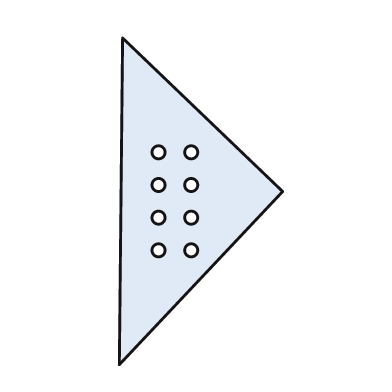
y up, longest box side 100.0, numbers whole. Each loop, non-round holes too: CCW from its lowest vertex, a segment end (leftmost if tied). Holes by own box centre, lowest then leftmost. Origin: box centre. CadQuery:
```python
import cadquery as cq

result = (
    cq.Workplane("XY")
    .moveTo(-25.0, -50.0)
    .lineTo(25.0, 3.0)
    .lineTo(-24.0, 50.0)
    .close()
    .moveTo(-13.0, -15.0)
    .circle(2.0)
    .moveTo(-3.0, -15.0)
    .circle(2.0)
    .moveTo(-13.0, -5.0)
    .circle(2.0)
    .moveTo(-3.0, -5.0)
    .circle(2.0)
    .moveTo(-13.0, 5.0)
    .circle(2.0)
    .moveTo(-3.0, 5.0)
    .circle(2.0)
    .moveTo(-13.0, 15.0)
    .circle(2.0)
    .moveTo(-3.0, 15.0)
    .circle(2.0)
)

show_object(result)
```